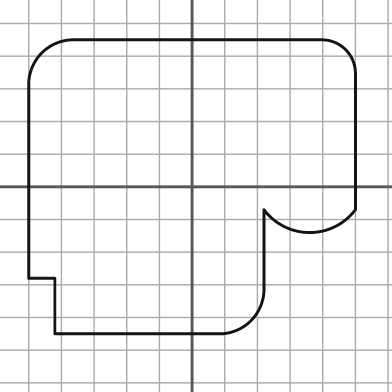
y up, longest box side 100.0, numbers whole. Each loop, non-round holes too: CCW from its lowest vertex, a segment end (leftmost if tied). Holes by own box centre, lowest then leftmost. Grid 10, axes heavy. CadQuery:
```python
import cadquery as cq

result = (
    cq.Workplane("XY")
    .moveTo(-42.0, -45.0)
    .lineTo(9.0, -45.0)
    .threePointArc((18.0, -41.0), (22.0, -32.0))
    .lineTo(22.0, -7.0)
    .threePointArc((36.0, -14.0), (50.0, -7.0))
    .lineTo(50.0, 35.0)
    .threePointArc((47.0, 42.0), (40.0, 45.0))
    .lineTo(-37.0, 45.0)
    .threePointArc((-46.0, 41.0), (-50.0, 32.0))
    .lineTo(-50.0, -28.0)
    .lineTo(-42.0, -28.0)
    .close()
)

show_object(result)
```